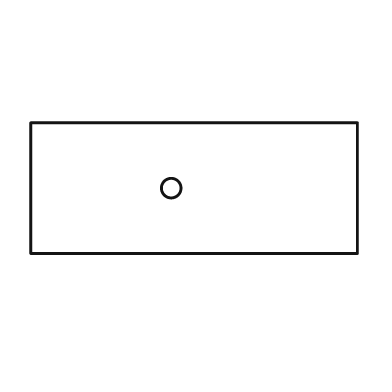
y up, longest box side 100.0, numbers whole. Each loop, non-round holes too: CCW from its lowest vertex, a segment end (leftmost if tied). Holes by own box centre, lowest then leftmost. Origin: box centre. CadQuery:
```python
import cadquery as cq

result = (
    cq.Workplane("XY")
    .moveTo(-50.0, -20.0)
    .lineTo(50.0, -20.0)
    .lineTo(50.0, 20.0)
    .lineTo(-50.0, 20.0)
    .close()
    .moveTo(-7.0, 0.0)
    .circle(3.0)
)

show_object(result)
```